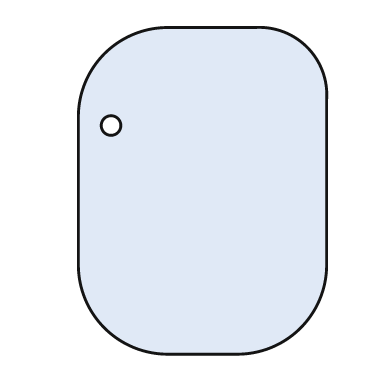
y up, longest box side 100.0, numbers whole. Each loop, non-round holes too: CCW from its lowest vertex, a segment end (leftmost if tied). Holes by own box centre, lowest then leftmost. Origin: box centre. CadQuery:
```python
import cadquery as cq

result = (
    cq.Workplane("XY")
    .moveTo(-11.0, -50.0)
    .lineTo(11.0, -50.0)
    .threePointArc((30.0, -42.0), (38.0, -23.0))
    .lineTo(38.0, 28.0)
    .threePointArc((32.0, 44.0), (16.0, 50.0))
    .lineTo(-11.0, 50.0)
    .threePointArc((-30.0, 42.0), (-38.0, 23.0))
    .lineTo(-38.0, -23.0)
    .threePointArc((-30.0, -42.0), (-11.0, -50.0))
    .close()
    .moveTo(-28.0, 20.0)
    .circle(3.0)
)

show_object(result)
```